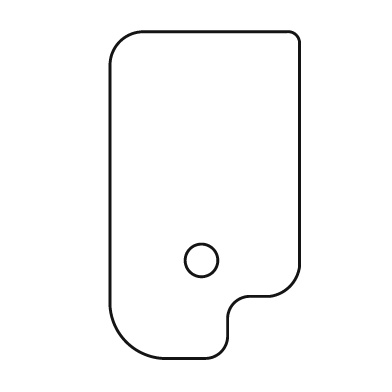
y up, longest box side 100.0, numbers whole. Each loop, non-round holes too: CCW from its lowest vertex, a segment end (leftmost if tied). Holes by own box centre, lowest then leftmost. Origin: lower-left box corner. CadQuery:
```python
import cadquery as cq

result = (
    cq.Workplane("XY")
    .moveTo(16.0, 0.0)
    .lineTo(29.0, 0.0)
    .threePointArc((34.0, 2.0), (36.0, 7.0))
    .lineTo(36.0, 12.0)
    .threePointArc((38.0, 17.0), (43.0, 19.0))
    .lineTo(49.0, 19.0)
    .threePointArc((55.0, 22.0), (58.0, 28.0))
    .lineTo(58.0, 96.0)
    .threePointArc((57.0, 99.0), (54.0, 100.0))
    .lineTo(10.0, 100.0)
    .threePointArc((3.0, 97.0), (0.0, 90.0))
    .lineTo(0.0, 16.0)
    .threePointArc((5.0, 5.0), (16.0, 0.0))
    .close()
    .moveTo(28.0, 30.0)
    .circle(5.0)
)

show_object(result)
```